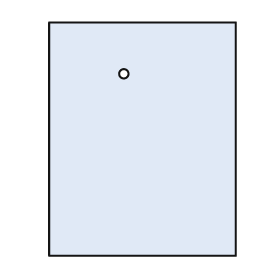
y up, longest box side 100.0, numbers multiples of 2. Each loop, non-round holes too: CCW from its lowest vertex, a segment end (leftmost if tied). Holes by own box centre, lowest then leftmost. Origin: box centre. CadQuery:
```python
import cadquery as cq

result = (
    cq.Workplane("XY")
    .moveTo(-40.0, -50.0)
    .lineTo(40.0, -50.0)
    .lineTo(40.0, 50.0)
    .lineTo(-40.0, 50.0)
    .close()
    .moveTo(-8.0, 28.0)
    .circle(2.0)
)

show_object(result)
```